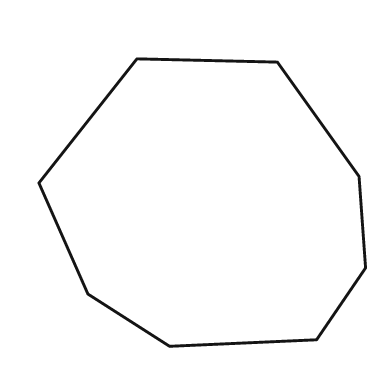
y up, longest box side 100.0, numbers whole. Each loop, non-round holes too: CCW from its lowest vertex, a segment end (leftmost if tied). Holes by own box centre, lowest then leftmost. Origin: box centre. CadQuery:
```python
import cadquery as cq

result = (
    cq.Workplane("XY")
    .moveTo(-10.0, -44.0)
    .lineTo(35.0, -42.0)
    .lineTo(50.0, -20.0)
    .lineTo(48.0, 8.0)
    .lineTo(23.0, 43.0)
    .lineTo(-20.0, 44.0)
    .lineTo(-50.0, 6.0)
    .lineTo(-35.0, -28.0)
    .close()
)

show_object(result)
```